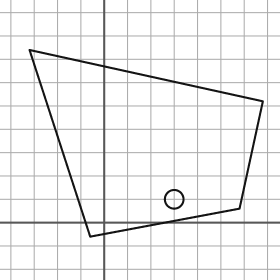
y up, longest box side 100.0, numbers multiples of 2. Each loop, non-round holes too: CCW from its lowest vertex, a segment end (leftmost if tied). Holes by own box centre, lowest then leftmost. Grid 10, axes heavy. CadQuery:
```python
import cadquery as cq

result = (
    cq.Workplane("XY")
    .moveTo(-6.0, -6.0)
    .lineTo(58.0, 6.0)
    .lineTo(68.0, 52.0)
    .lineTo(-32.0, 74.0)
    .close()
    .moveTo(30.0, 10.0)
    .circle(4.0)
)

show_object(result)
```